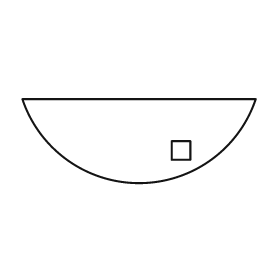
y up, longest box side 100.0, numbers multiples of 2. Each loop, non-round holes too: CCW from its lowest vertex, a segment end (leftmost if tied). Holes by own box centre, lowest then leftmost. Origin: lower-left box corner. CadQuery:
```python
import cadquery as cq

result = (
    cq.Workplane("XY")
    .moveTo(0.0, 36.0)
    .threePointArc((50.0, 0.0), (100.0, 36.0))
    .close()
    .moveTo(64.0, 10.0)
    .lineTo(72.0, 10.0)
    .lineTo(72.0, 18.0)
    .lineTo(64.0, 18.0)
    .close()
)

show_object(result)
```